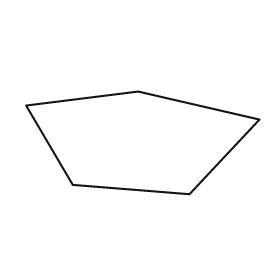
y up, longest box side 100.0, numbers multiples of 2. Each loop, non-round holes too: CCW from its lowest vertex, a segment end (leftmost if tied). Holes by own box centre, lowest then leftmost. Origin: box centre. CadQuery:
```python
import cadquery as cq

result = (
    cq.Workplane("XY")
    .moveTo(20.0, -22.0)
    .lineTo(50.0, 10.0)
    .lineTo(-2.0, 22.0)
    .lineTo(-50.0, 16.0)
    .lineTo(-30.0, -18.0)
    .close()
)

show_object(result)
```